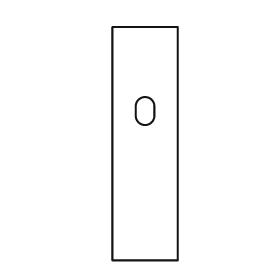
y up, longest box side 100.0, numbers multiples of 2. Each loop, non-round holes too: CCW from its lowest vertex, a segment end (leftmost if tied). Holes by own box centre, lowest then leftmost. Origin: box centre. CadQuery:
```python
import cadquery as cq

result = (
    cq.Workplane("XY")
    .moveTo(-14.0, -50.0)
    .lineTo(14.0, -50.0)
    .lineTo(14.0, 50.0)
    .lineTo(-14.0, 50.0)
    .close()
    .moveTo(-4.0, 12.0)
    .threePointArc((0.0, 8.0), (4.0, 12.0))
    .lineTo(4.0, 16.0)
    .threePointArc((0.0, 20.0), (-4.0, 16.0))
    .close()
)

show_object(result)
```